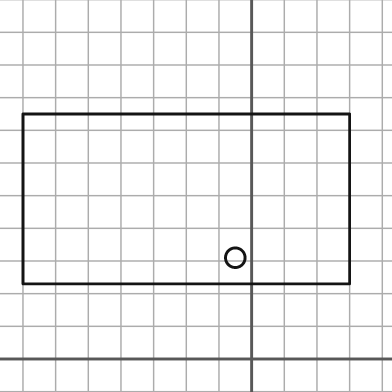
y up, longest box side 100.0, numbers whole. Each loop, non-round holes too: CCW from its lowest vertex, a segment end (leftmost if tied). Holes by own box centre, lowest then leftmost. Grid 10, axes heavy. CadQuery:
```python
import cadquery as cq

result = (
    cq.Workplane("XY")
    .moveTo(-70.0, 23.0)
    .lineTo(30.0, 23.0)
    .lineTo(30.0, 75.0)
    .lineTo(-70.0, 75.0)
    .close()
    .moveTo(-5.0, 31.0)
    .circle(3.0)
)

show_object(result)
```